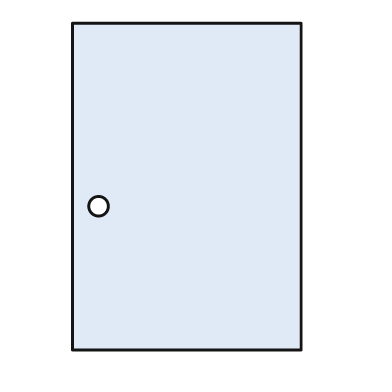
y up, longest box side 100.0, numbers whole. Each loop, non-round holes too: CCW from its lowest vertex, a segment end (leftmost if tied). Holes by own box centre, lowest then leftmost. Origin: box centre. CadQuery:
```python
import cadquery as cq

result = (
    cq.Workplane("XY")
    .moveTo(-35.0, -50.0)
    .lineTo(35.0, -50.0)
    .lineTo(35.0, 50.0)
    .lineTo(-35.0, 50.0)
    .close()
    .moveTo(-27.0, -6.0)
    .circle(3.0)
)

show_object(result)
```